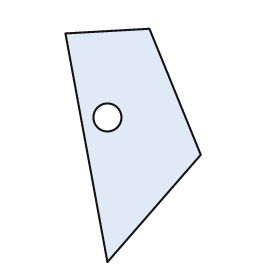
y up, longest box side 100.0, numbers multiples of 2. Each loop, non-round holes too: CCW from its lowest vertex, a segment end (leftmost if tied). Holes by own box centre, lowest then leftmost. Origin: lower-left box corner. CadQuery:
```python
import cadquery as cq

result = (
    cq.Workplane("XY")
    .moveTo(18.0, 0.0)
    .lineTo(58.0, 46.0)
    .lineTo(36.0, 100.0)
    .lineTo(0.0, 98.0)
    .close()
    .moveTo(18.0, 62.0)
    .circle(6.0)
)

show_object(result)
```